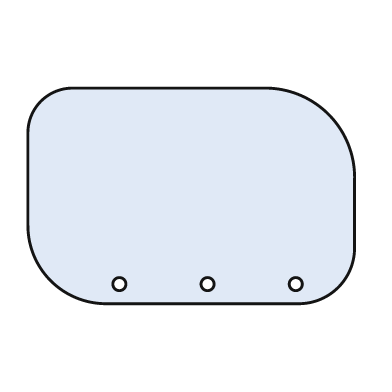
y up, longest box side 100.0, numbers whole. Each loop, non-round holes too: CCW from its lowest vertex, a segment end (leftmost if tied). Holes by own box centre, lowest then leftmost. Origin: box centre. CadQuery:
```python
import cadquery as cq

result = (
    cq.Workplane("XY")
    .moveTo(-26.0, -33.0)
    .lineTo(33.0, -33.0)
    .threePointArc((45.0, -28.0), (50.0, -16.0))
    .lineTo(50.0, 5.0)
    .threePointArc((42.0, 25.0), (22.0, 33.0))
    .lineTo(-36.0, 33.0)
    .threePointArc((-46.0, 29.0), (-50.0, 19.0))
    .lineTo(-50.0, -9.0)
    .threePointArc((-43.0, -26.0), (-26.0, -33.0))
    .close()
    .moveTo(-22.0, -27.0)
    .circle(2.0)
    .moveTo(5.0, -27.0)
    .circle(2.0)
    .moveTo(32.0, -27.0)
    .circle(2.0)
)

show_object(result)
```